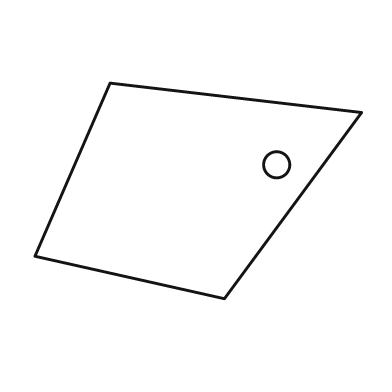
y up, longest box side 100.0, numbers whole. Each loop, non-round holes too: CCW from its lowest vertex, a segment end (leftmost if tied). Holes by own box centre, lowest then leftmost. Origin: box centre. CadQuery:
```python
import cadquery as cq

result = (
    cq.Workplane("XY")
    .moveTo(8.0, -33.0)
    .lineTo(50.0, 24.0)
    .lineTo(-27.0, 33.0)
    .lineTo(-50.0, -20.0)
    .close()
    .moveTo(24.0, 8.0)
    .circle(4.0)
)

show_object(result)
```